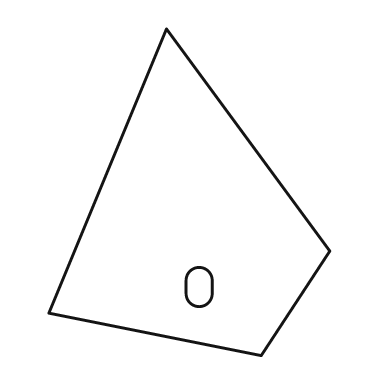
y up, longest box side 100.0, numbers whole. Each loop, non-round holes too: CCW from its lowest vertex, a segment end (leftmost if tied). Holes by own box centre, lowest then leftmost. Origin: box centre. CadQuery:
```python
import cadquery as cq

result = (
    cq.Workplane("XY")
    .moveTo(22.0, -50.0)
    .lineTo(43.0, -18.0)
    .lineTo(-7.0, 50.0)
    .lineTo(-43.0, -37.0)
    .close()
    .moveTo(-1.0, -31.0)
    .threePointArc((3.0, -35.0), (7.0, -31.0))
    .lineTo(7.0, -27.0)
    .threePointArc((3.0, -23.0), (-1.0, -27.0))
    .close()
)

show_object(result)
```